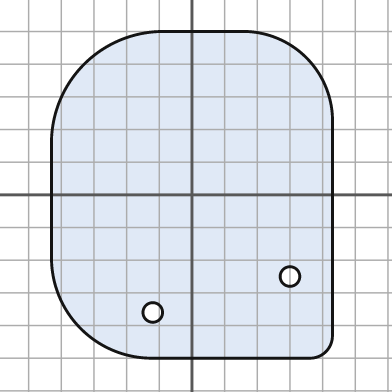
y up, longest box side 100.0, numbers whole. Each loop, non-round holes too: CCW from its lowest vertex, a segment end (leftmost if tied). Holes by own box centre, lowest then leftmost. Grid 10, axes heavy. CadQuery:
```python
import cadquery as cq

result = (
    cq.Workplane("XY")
    .moveTo(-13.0, -50.0)
    .lineTo(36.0, -50.0)
    .threePointArc((41.0, -48.0), (43.0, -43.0))
    .lineTo(43.0, 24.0)
    .threePointArc((35.0, 42.0), (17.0, 50.0))
    .lineTo(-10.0, 50.0)
    .threePointArc((-33.0, 40.0), (-43.0, 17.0))
    .lineTo(-43.0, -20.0)
    .threePointArc((-34.0, -41.0), (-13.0, -50.0))
    .close()
    .moveTo(-12.0, -36.0)
    .circle(3.0)
    .moveTo(30.0, -25.0)
    .circle(3.0)
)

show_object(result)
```